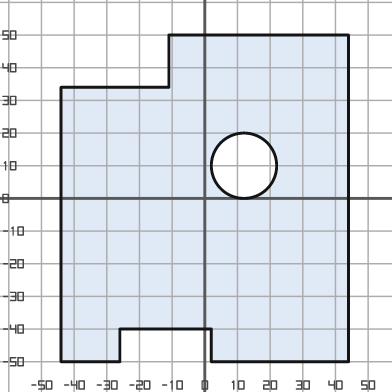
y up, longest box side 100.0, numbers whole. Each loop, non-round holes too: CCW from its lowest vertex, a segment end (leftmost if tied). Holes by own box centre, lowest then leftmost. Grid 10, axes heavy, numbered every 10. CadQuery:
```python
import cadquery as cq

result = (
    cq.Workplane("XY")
    .moveTo(-44.0, -50.0)
    .lineTo(-26.0, -50.0)
    .lineTo(-26.0, -40.0)
    .lineTo(2.0, -40.0)
    .lineTo(2.0, -50.0)
    .lineTo(44.0, -50.0)
    .lineTo(44.0, 50.0)
    .lineTo(-11.0, 50.0)
    .lineTo(-11.0, 34.0)
    .lineTo(-44.0, 34.0)
    .close()
    .moveTo(12.0, 10.0)
    .circle(10.0)
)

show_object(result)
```